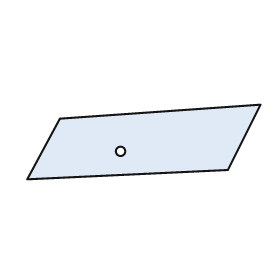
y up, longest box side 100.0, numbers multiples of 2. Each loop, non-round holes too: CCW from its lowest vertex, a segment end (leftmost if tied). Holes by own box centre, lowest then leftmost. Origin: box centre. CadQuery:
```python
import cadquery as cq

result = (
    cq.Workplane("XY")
    .moveTo(-50.0, -16.0)
    .lineTo(36.0, -12.0)
    .lineTo(50.0, 16.0)
    .lineTo(-36.0, 10.0)
    .close()
    .moveTo(-10.0, -4.0)
    .circle(2.0)
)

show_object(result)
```